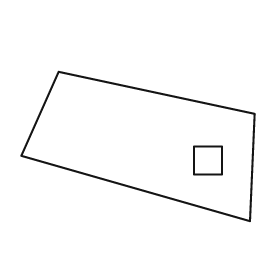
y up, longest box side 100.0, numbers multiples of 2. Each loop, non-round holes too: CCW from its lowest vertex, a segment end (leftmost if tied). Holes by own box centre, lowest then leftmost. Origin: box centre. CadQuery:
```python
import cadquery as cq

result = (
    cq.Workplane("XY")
    .moveTo(48.0, -32.0)
    .lineTo(50.0, 14.0)
    .lineTo(-34.0, 32.0)
    .lineTo(-50.0, -4.0)
    .close()
    .moveTo(24.0, -12.0)
    .lineTo(36.0, -12.0)
    .lineTo(36.0, 0.0)
    .lineTo(24.0, 0.0)
    .close()
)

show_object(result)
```